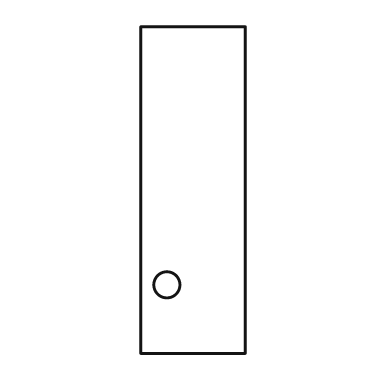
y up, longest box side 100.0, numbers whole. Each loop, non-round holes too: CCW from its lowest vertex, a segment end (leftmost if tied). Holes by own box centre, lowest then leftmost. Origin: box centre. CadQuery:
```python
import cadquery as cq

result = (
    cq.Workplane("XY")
    .moveTo(-16.0, -50.0)
    .lineTo(16.0, -50.0)
    .lineTo(16.0, 50.0)
    .lineTo(-16.0, 50.0)
    .close()
    .moveTo(-8.0, -29.0)
    .circle(4.0)
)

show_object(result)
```